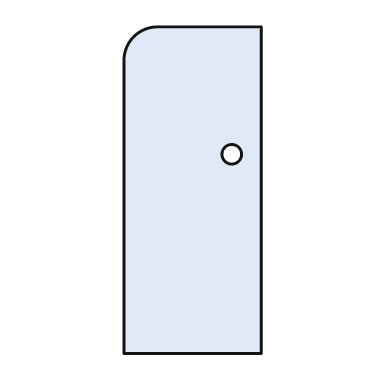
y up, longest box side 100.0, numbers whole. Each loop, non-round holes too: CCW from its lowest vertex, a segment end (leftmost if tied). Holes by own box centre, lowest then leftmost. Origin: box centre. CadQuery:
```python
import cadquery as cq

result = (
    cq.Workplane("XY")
    .moveTo(-21.0, -50.0)
    .lineTo(21.0, -50.0)
    .lineTo(21.0, 50.0)
    .lineTo(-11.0, 50.0)
    .threePointArc((-18.0, 47.0), (-21.0, 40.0))
    .close()
    .moveTo(12.0, 11.0)
    .circle(3.0)
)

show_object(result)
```